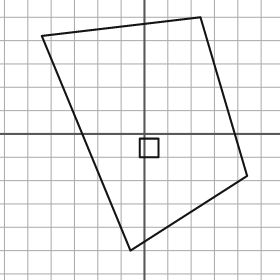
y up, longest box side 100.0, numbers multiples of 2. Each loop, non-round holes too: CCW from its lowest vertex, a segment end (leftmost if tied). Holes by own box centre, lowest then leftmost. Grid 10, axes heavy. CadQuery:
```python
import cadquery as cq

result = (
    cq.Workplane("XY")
    .moveTo(-6.0, -50.0)
    .lineTo(44.0, -18.0)
    .lineTo(24.0, 50.0)
    .lineTo(-44.0, 42.0)
    .close()
    .moveTo(-2.0, -10.0)
    .lineTo(6.0, -10.0)
    .lineTo(6.0, -2.0)
    .lineTo(-2.0, -2.0)
    .close()
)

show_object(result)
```